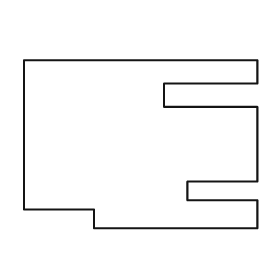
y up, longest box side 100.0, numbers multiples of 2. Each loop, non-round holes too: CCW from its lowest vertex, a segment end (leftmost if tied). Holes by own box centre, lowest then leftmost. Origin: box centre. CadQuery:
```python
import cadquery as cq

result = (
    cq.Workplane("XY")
    .moveTo(-20.0, -36.0)
    .lineTo(50.0, -36.0)
    .lineTo(50.0, -24.0)
    .lineTo(20.0, -24.0)
    .lineTo(20.0, -16.0)
    .lineTo(50.0, -16.0)
    .lineTo(50.0, 16.0)
    .lineTo(10.0, 16.0)
    .lineTo(10.0, 26.0)
    .lineTo(50.0, 26.0)
    .lineTo(50.0, 36.0)
    .lineTo(-50.0, 36.0)
    .lineTo(-50.0, -28.0)
    .lineTo(-20.0, -28.0)
    .close()
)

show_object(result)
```